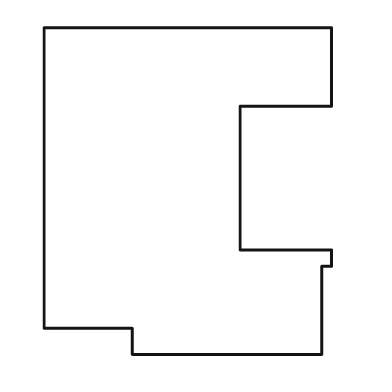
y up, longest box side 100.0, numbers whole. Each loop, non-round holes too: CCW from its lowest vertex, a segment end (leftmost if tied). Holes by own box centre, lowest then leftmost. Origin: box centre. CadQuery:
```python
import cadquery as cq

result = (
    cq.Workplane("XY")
    .moveTo(-17.0, -50.0)
    .lineTo(41.0, -50.0)
    .lineTo(41.0, -23.0)
    .lineTo(44.0, -23.0)
    .lineTo(44.0, -18.0)
    .lineTo(16.0, -18.0)
    .lineTo(16.0, 26.0)
    .lineTo(44.0, 26.0)
    .lineTo(44.0, 50.0)
    .lineTo(-44.0, 50.0)
    .lineTo(-44.0, -42.0)
    .lineTo(-17.0, -42.0)
    .close()
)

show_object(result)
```